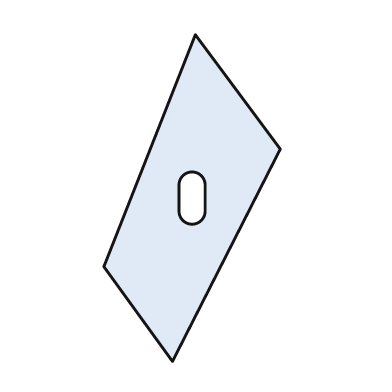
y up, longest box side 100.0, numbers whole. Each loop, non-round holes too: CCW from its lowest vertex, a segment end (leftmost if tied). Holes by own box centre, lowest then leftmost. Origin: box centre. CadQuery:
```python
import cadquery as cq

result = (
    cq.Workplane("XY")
    .moveTo(-6.0, -50.0)
    .lineTo(27.0, 15.0)
    .lineTo(1.0, 50.0)
    .lineTo(-27.0, -21.0)
    .close()
    .moveTo(-4.0, -4.0)
    .threePointArc((0.0, -8.0), (4.0, -4.0))
    .lineTo(4.0, 4.0)
    .threePointArc((0.0, 8.0), (-4.0, 4.0))
    .close()
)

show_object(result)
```